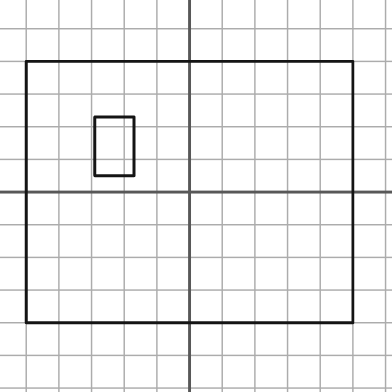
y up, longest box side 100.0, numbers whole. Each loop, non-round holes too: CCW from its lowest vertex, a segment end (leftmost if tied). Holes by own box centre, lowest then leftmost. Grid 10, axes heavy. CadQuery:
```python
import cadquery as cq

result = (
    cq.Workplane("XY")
    .moveTo(-50.0, -40.0)
    .lineTo(50.0, -40.0)
    .lineTo(50.0, 40.0)
    .lineTo(-50.0, 40.0)
    .close()
    .moveTo(-29.0, 5.0)
    .lineTo(-17.0, 5.0)
    .lineTo(-17.0, 23.0)
    .lineTo(-29.0, 23.0)
    .close()
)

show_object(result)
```